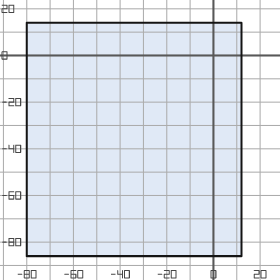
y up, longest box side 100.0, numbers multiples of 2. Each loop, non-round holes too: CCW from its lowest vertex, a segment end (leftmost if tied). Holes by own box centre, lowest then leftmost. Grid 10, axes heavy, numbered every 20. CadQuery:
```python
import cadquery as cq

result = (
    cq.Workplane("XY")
    .moveTo(-80.0, -86.0)
    .lineTo(12.0, -86.0)
    .lineTo(12.0, 14.0)
    .lineTo(-80.0, 14.0)
    .close()
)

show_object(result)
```